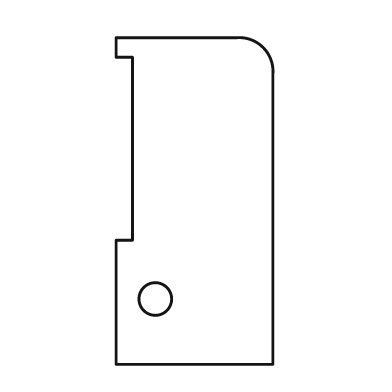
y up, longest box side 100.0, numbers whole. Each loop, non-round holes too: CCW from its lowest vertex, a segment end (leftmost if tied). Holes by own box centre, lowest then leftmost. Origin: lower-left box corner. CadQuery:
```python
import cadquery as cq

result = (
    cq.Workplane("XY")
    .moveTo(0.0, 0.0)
    .lineTo(48.0, 0.0)
    .lineTo(48.0, 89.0)
    .threePointArc((45.0, 97.0), (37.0, 100.0))
    .lineTo(0.0, 100.0)
    .lineTo(0.0, 94.0)
    .lineTo(5.0, 94.0)
    .lineTo(5.0, 38.0)
    .lineTo(0.0, 38.0)
    .close()
    .moveTo(12.0, 20.0)
    .circle(5.0)
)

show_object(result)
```